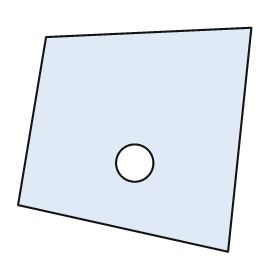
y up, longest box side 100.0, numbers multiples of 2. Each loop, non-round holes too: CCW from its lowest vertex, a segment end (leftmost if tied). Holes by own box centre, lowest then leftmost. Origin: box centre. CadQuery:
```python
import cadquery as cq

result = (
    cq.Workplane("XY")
    .moveTo(40.0, -48.0)
    .lineTo(50.0, 48.0)
    .lineTo(-38.0, 44.0)
    .lineTo(-50.0, -28.0)
    .close()
    .moveTo(0.0, -10.0)
    .circle(8.0)
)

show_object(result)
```